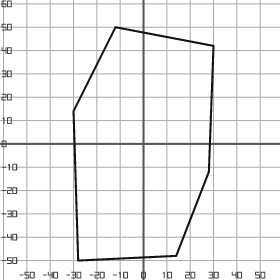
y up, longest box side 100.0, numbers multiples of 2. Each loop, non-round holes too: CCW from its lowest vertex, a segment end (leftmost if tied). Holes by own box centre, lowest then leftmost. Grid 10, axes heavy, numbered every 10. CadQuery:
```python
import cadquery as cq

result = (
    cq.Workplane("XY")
    .moveTo(-28.0, -50.0)
    .lineTo(14.0, -48.0)
    .lineTo(28.0, -12.0)
    .lineTo(30.0, 42.0)
    .lineTo(-12.0, 50.0)
    .lineTo(-30.0, 14.0)
    .close()
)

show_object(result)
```